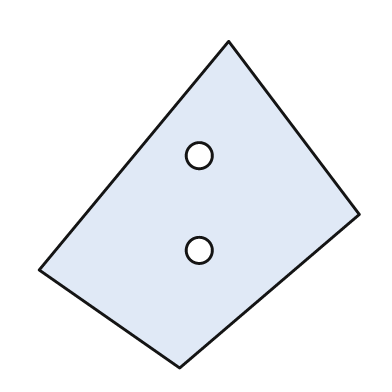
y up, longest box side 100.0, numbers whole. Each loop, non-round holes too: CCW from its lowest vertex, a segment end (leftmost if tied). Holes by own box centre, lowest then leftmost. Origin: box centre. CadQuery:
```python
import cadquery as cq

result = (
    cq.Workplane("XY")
    .moveTo(-6.0, -50.0)
    .lineTo(49.0, -3.0)
    .lineTo(9.0, 50.0)
    .lineTo(-49.0, -20.0)
    .close()
    .moveTo(0.0, -14.0)
    .circle(4.0)
    .moveTo(0.0, 15.0)
    .circle(4.0)
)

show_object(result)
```